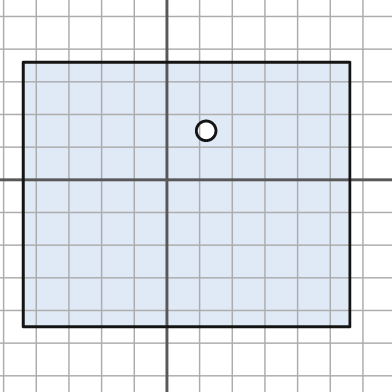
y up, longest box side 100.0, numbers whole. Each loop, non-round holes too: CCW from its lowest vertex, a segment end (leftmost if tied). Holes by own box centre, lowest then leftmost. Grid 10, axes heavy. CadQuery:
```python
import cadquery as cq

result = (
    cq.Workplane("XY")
    .moveTo(-44.0, -45.0)
    .lineTo(56.0, -45.0)
    .lineTo(56.0, 36.0)
    .lineTo(-44.0, 36.0)
    .close()
    .moveTo(12.0, 15.0)
    .circle(3.0)
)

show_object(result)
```